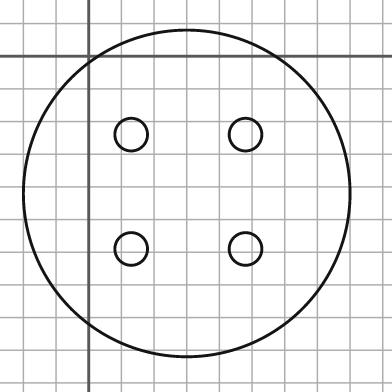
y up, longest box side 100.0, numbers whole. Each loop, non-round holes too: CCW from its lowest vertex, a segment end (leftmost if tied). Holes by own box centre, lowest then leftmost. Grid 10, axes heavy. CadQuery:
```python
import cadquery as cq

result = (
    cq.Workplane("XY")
    .moveTo(30.0, -42.0)
    .circle(50.0)
    .moveTo(13.0, -59.0)
    .circle(5.0)
    .moveTo(48.0, -59.0)
    .circle(5.0)
    .moveTo(13.0, -24.0)
    .circle(5.0)
    .moveTo(48.0, -24.0)
    .circle(5.0)
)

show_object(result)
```